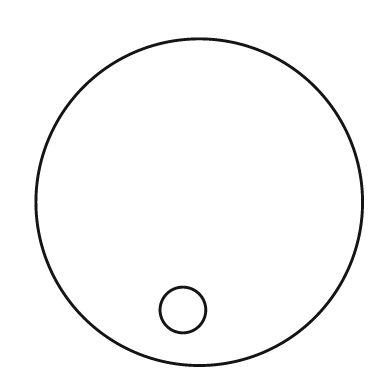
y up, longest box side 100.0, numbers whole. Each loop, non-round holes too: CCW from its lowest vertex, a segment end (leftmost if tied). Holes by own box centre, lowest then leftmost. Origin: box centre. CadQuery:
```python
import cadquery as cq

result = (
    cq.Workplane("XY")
    .moveTo(0.0, 0.0)
    .circle(50.0)
    .moveTo(-5.0, -33.0)
    .circle(7.0)
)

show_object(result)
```